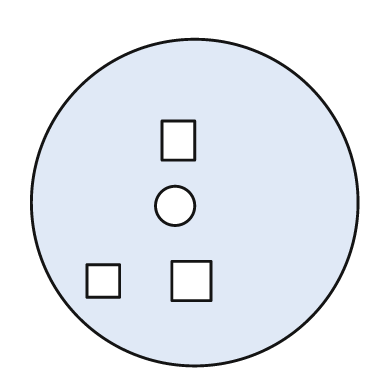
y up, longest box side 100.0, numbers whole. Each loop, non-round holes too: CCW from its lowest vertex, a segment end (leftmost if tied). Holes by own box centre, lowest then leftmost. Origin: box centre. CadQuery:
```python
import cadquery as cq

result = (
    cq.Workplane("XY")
    .moveTo(0.0, 0.0)
    .circle(50.0)
    .moveTo(-33.0, -29.0)
    .lineTo(-23.0, -29.0)
    .lineTo(-23.0, -19.0)
    .lineTo(-33.0, -19.0)
    .close()
    .moveTo(-7.0, -30.0)
    .lineTo(5.0, -30.0)
    .lineTo(5.0, -18.0)
    .lineTo(-7.0, -18.0)
    .close()
    .moveTo(-6.0, -1.0)
    .circle(6.0)
    .moveTo(-10.0, 13.0)
    .lineTo(0.0, 13.0)
    .lineTo(0.0, 25.0)
    .lineTo(-10.0, 25.0)
    .close()
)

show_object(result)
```